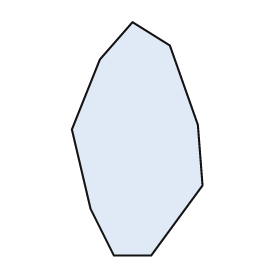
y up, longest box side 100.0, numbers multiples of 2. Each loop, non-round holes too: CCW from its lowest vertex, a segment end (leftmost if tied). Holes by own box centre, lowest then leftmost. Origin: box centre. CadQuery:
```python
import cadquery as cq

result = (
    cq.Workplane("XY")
    .moveTo(-10.0, -50.0)
    .lineTo(6.0, -50.0)
    .lineTo(28.0, -20.0)
    .lineTo(26.0, 6.0)
    .lineTo(14.0, 40.0)
    .lineTo(-2.0, 50.0)
    .lineTo(-16.0, 34.0)
    .lineTo(-28.0, 4.0)
    .lineTo(-20.0, -30.0)
    .close()
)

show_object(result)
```